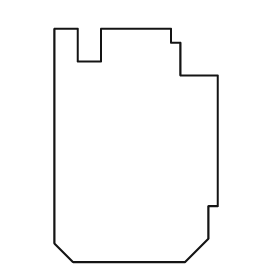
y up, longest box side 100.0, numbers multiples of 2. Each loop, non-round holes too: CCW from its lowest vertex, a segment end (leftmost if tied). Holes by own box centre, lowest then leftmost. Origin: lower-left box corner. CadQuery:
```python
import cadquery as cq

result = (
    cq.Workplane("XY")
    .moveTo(8.0, 0.0)
    .lineTo(56.0, 0.0)
    .lineTo(66.0, 10.0)
    .lineTo(66.0, 24.0)
    .lineTo(70.0, 24.0)
    .lineTo(70.0, 80.0)
    .lineTo(54.0, 80.0)
    .lineTo(54.0, 94.0)
    .lineTo(50.0, 94.0)
    .lineTo(50.0, 100.0)
    .lineTo(20.0, 100.0)
    .lineTo(20.0, 86.0)
    .lineTo(10.0, 86.0)
    .lineTo(10.0, 100.0)
    .lineTo(0.0, 100.0)
    .lineTo(0.0, 8.0)
    .close()
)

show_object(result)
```